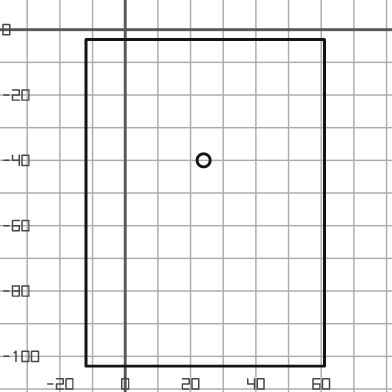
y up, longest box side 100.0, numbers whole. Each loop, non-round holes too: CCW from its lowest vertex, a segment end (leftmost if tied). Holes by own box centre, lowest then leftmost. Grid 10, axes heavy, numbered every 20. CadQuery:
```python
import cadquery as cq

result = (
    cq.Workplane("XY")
    .moveTo(-12.0, -103.0)
    .lineTo(61.0, -103.0)
    .lineTo(61.0, -3.0)
    .lineTo(-12.0, -3.0)
    .close()
    .moveTo(24.0, -40.0)
    .circle(2.0)
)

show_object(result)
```